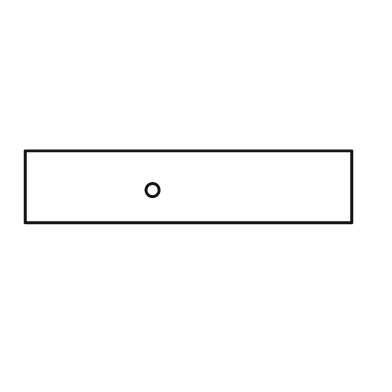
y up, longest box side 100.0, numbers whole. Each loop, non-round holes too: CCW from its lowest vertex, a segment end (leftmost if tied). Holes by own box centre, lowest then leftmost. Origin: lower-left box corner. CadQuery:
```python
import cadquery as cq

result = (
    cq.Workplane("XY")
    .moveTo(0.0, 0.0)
    .lineTo(100.0, 0.0)
    .lineTo(100.0, 22.0)
    .lineTo(0.0, 22.0)
    .close()
    .moveTo(39.0, 10.0)
    .circle(2.0)
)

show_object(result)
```